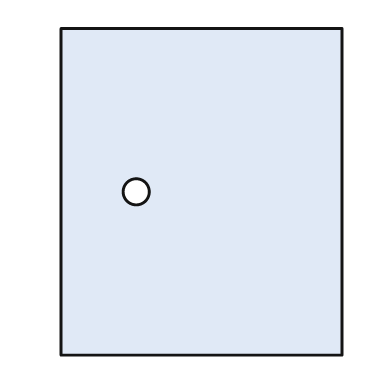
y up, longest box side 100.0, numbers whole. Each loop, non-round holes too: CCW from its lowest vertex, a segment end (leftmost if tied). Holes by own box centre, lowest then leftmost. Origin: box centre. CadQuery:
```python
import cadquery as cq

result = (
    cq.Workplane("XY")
    .moveTo(-43.0, -50.0)
    .lineTo(43.0, -50.0)
    .lineTo(43.0, 50.0)
    .lineTo(-43.0, 50.0)
    .close()
    .moveTo(-20.0, 0.0)
    .circle(4.0)
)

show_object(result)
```